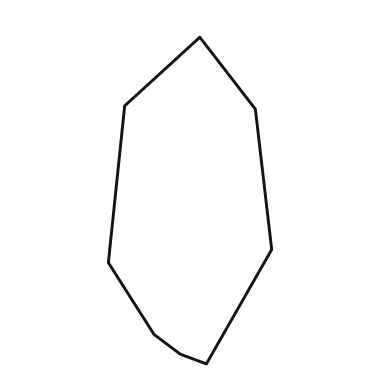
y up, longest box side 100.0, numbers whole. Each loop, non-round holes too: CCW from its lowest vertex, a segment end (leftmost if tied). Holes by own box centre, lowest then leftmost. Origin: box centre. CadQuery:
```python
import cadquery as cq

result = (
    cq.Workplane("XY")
    .moveTo(5.0, -50.0)
    .lineTo(25.0, -15.0)
    .lineTo(20.0, 28.0)
    .lineTo(3.0, 50.0)
    .lineTo(-20.0, 29.0)
    .lineTo(-25.0, -19.0)
    .lineTo(-11.0, -41.0)
    .lineTo(-3.0, -47.0)
    .close()
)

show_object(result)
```